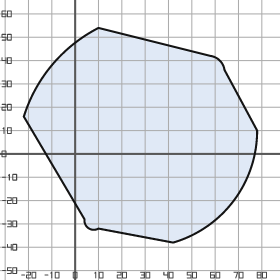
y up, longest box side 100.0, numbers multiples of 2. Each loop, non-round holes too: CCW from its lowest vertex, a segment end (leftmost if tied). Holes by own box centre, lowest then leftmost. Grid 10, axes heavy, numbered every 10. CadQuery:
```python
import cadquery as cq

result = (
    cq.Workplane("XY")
    .moveTo(42.0, -38.0)
    .threePointArc((68.0, -20.0), (78.0, 10.0))
    .lineTo(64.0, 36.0)
    .threePointArc((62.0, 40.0), (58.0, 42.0))
    .lineTo(10.0, 54.0)
    .threePointArc((-10.0, 38.0), (-22.0, 16.0))
    .lineTo(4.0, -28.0)
    .threePointArc((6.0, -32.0), (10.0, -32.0))
    .close()
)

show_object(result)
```